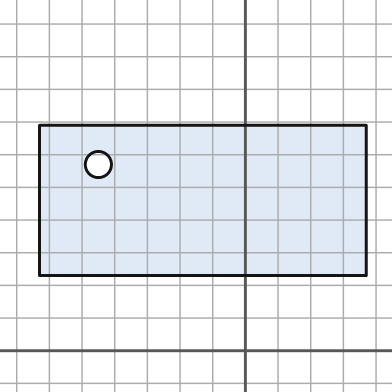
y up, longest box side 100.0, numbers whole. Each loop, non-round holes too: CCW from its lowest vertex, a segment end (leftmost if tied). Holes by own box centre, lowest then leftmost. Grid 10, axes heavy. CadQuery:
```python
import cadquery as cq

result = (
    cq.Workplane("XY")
    .moveTo(-63.0, 23.0)
    .lineTo(37.0, 23.0)
    .lineTo(37.0, 69.0)
    .lineTo(-63.0, 69.0)
    .close()
    .moveTo(-45.0, 57.0)
    .circle(4.0)
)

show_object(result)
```